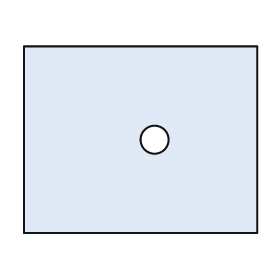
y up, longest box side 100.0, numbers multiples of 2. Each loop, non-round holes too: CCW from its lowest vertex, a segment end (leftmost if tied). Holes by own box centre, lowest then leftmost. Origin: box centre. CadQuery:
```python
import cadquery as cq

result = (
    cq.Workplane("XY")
    .moveTo(-50.0, -40.0)
    .lineTo(50.0, -40.0)
    .lineTo(50.0, 40.0)
    .lineTo(-50.0, 40.0)
    .close()
    .moveTo(6.0, 0.0)
    .circle(6.0)
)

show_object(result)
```